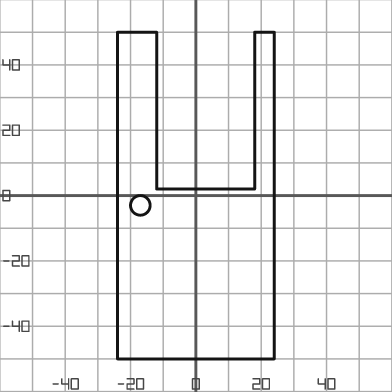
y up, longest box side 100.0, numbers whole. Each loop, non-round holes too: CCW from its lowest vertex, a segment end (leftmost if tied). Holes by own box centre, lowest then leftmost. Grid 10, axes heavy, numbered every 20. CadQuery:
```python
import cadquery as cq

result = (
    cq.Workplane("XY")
    .moveTo(-24.0, -50.0)
    .lineTo(24.0, -50.0)
    .lineTo(24.0, 50.0)
    .lineTo(18.0, 50.0)
    .lineTo(18.0, 2.0)
    .lineTo(-12.0, 2.0)
    .lineTo(-12.0, 50.0)
    .lineTo(-24.0, 50.0)
    .close()
    .moveTo(-17.0, -3.0)
    .circle(3.0)
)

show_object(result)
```